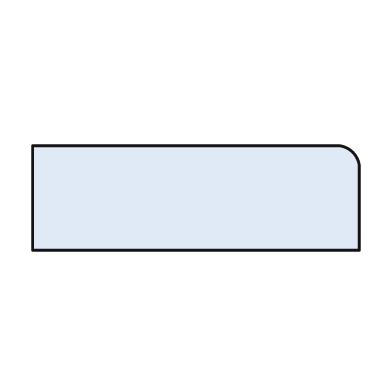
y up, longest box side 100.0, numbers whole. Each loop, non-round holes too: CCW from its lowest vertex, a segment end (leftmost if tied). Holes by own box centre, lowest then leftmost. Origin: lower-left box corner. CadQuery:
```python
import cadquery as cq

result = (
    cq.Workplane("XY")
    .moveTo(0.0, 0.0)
    .lineTo(100.0, 0.0)
    .lineTo(100.0, 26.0)
    .threePointArc((98.0, 30.0), (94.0, 32.0))
    .lineTo(0.0, 32.0)
    .close()
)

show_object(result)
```